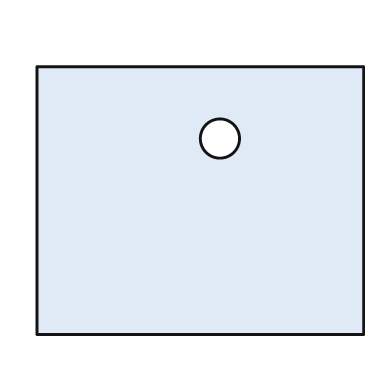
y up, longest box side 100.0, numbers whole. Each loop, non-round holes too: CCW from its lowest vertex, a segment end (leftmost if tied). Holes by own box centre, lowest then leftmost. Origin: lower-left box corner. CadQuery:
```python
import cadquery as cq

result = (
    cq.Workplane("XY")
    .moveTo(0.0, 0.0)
    .lineTo(100.0, 0.0)
    .lineTo(100.0, 82.0)
    .lineTo(0.0, 82.0)
    .close()
    .moveTo(56.0, 60.0)
    .circle(6.0)
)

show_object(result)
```